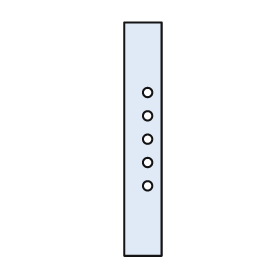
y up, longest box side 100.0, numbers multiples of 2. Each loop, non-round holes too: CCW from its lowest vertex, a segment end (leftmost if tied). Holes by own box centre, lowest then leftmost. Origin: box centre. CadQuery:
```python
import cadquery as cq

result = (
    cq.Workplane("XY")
    .moveTo(-8.0, -50.0)
    .lineTo(8.0, -50.0)
    .lineTo(8.0, 50.0)
    .lineTo(-8.0, 50.0)
    .close()
    .moveTo(2.0, -20.0)
    .circle(2.0)
    .moveTo(2.0, -10.0)
    .circle(2.0)
    .moveTo(2.0, 0.0)
    .circle(2.0)
    .moveTo(2.0, 10.0)
    .circle(2.0)
    .moveTo(2.0, 20.0)
    .circle(2.0)
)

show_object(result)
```